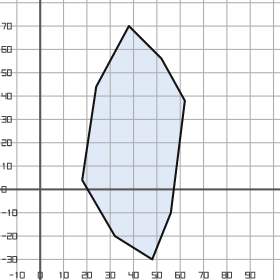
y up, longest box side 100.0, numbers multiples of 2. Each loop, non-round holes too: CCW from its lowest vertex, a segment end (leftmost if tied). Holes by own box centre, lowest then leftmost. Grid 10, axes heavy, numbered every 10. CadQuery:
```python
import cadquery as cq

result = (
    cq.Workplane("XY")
    .moveTo(48.0, -30.0)
    .lineTo(56.0, -10.0)
    .lineTo(62.0, 38.0)
    .lineTo(52.0, 56.0)
    .lineTo(38.0, 70.0)
    .lineTo(24.0, 44.0)
    .lineTo(18.0, 4.0)
    .lineTo(32.0, -20.0)
    .close()
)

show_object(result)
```